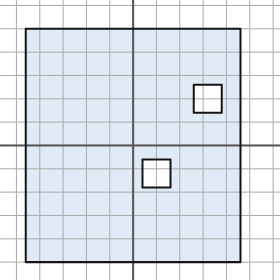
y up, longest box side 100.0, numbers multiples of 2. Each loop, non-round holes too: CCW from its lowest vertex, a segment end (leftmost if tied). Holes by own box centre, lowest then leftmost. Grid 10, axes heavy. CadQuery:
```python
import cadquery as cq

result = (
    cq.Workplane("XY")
    .moveTo(-46.0, -50.0)
    .lineTo(46.0, -50.0)
    .lineTo(46.0, 50.0)
    .lineTo(-46.0, 50.0)
    .close()
    .moveTo(4.0, -18.0)
    .lineTo(16.0, -18.0)
    .lineTo(16.0, -6.0)
    .lineTo(4.0, -6.0)
    .close()
    .moveTo(26.0, 14.0)
    .lineTo(38.0, 14.0)
    .lineTo(38.0, 26.0)
    .lineTo(26.0, 26.0)
    .close()
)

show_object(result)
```